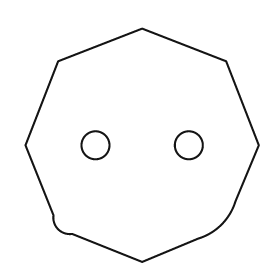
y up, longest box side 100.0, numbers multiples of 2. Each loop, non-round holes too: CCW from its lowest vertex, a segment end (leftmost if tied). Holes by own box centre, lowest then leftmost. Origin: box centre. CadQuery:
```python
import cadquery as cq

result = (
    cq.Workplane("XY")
    .moveTo(0.0, -50.0)
    .lineTo(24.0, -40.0)
    .threePointArc((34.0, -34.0), (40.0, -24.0))
    .lineTo(50.0, 0.0)
    .lineTo(36.0, 36.0)
    .lineTo(0.0, 50.0)
    .lineTo(-36.0, 36.0)
    .lineTo(-50.0, 0.0)
    .lineTo(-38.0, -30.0)
    .threePointArc((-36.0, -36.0), (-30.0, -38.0))
    .close()
    .moveTo(-20.0, 0.0)
    .circle(6.0)
    .moveTo(20.0, 0.0)
    .circle(6.0)
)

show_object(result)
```